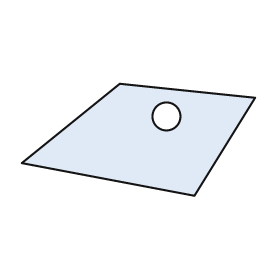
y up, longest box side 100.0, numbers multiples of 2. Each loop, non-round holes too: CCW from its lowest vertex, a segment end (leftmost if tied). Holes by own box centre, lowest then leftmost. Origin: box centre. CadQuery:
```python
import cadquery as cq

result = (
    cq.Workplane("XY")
    .moveTo(24.0, -24.0)
    .lineTo(50.0, 18.0)
    .lineTo(-8.0, 24.0)
    .lineTo(-50.0, -10.0)
    .close()
    .moveTo(12.0, 10.0)
    .circle(6.0)
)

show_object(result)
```